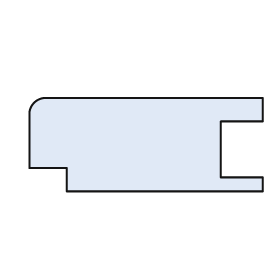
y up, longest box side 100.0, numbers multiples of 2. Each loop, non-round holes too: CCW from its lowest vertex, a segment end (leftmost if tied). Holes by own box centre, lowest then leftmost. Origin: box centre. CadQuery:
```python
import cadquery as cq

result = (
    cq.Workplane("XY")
    .moveTo(-34.0, -20.0)
    .lineTo(50.0, -20.0)
    .lineTo(50.0, -14.0)
    .lineTo(32.0, -14.0)
    .lineTo(32.0, 10.0)
    .lineTo(50.0, 10.0)
    .lineTo(50.0, 20.0)
    .lineTo(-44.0, 20.0)
    .threePointArc((-48.0, 18.0), (-50.0, 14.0))
    .lineTo(-50.0, -10.0)
    .lineTo(-34.0, -10.0)
    .close()
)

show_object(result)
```